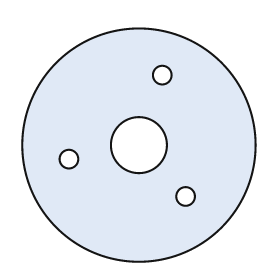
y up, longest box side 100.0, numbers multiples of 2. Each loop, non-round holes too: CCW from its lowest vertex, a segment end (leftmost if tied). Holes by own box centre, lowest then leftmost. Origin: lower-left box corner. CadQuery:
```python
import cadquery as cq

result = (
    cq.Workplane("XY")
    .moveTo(50.0, 50.0)
    .circle(50.0)
    .moveTo(70.0, 28.0)
    .circle(4.0)
    .moveTo(20.0, 44.0)
    .circle(4.0)
    .moveTo(50.0, 50.0)
    .circle(12.0)
    .moveTo(60.0, 80.0)
    .circle(4.0)
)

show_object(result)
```